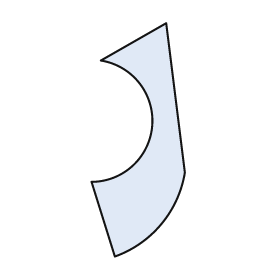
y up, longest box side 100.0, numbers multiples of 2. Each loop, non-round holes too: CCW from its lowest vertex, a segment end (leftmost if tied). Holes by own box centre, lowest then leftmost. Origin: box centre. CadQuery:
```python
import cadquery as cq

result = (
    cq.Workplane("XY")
    .moveTo(-10.0, -50.0)
    .threePointArc((10.0, -36.0), (20.0, -14.0))
    .lineTo(12.0, 50.0)
    .lineTo(-16.0, 34.0)
    .threePointArc((6.0, 6.0), (-20.0, -18.0))
    .close()
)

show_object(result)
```